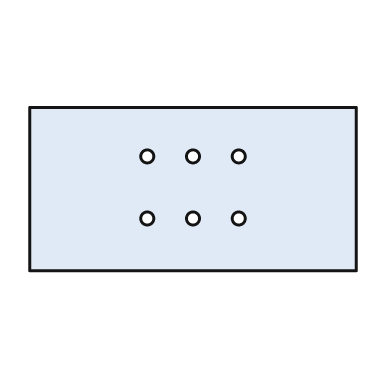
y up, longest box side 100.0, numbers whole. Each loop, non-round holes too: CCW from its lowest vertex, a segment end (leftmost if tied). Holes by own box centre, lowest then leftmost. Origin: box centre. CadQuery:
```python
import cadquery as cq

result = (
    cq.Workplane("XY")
    .moveTo(-50.0, -25.0)
    .lineTo(50.0, -25.0)
    .lineTo(50.0, 25.0)
    .lineTo(-50.0, 25.0)
    .close()
    .moveTo(-14.0, -9.0)
    .circle(2.0)
    .moveTo(0.0, -9.0)
    .circle(2.0)
    .moveTo(14.0, -9.0)
    .circle(2.0)
    .moveTo(-14.0, 10.0)
    .circle(2.0)
    .moveTo(0.0, 10.0)
    .circle(2.0)
    .moveTo(14.0, 10.0)
    .circle(2.0)
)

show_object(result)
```